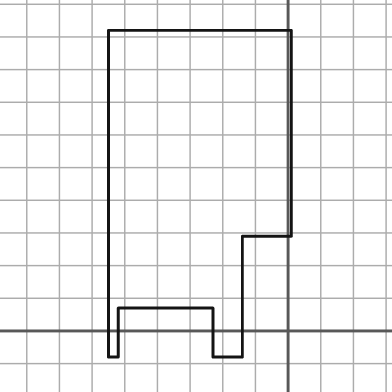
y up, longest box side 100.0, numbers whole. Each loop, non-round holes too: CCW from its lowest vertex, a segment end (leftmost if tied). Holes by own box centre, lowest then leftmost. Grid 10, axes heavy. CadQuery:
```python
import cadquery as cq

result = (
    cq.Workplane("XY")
    .moveTo(-55.0, -8.0)
    .lineTo(-52.0, -8.0)
    .lineTo(-52.0, 7.0)
    .lineTo(-23.0, 7.0)
    .lineTo(-23.0, -8.0)
    .lineTo(-14.0, -8.0)
    .lineTo(-14.0, 29.0)
    .lineTo(1.0, 29.0)
    .lineTo(1.0, 92.0)
    .lineTo(-55.0, 92.0)
    .close()
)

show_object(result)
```